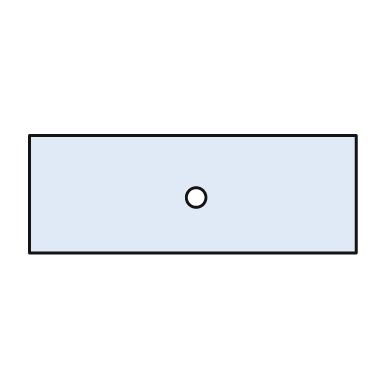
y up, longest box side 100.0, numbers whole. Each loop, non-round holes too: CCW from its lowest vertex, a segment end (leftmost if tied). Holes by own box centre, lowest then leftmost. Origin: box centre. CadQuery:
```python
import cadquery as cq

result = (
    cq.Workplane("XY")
    .moveTo(-50.0, -18.0)
    .lineTo(50.0, -18.0)
    .lineTo(50.0, 18.0)
    .lineTo(-50.0, 18.0)
    .close()
    .moveTo(1.0, -1.0)
    .circle(3.0)
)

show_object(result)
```